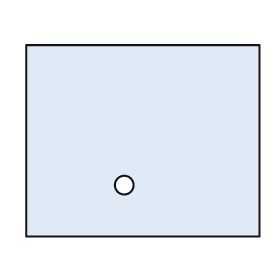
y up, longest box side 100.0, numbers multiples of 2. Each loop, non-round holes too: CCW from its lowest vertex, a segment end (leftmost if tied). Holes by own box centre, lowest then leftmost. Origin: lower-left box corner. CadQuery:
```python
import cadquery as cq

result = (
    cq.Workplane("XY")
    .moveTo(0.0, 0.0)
    .lineTo(100.0, 0.0)
    .lineTo(100.0, 82.0)
    .lineTo(0.0, 82.0)
    .close()
    .moveTo(42.0, 22.0)
    .circle(4.0)
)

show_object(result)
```